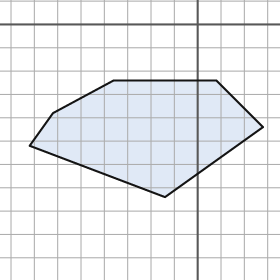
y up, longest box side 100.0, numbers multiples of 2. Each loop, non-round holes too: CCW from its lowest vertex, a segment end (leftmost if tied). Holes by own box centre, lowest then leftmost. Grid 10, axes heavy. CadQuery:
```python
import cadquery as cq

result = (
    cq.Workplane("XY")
    .moveTo(-14.0, -74.0)
    .lineTo(28.0, -44.0)
    .lineTo(8.0, -24.0)
    .lineTo(-36.0, -24.0)
    .lineTo(-62.0, -38.0)
    .lineTo(-72.0, -52.0)
    .close()
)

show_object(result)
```